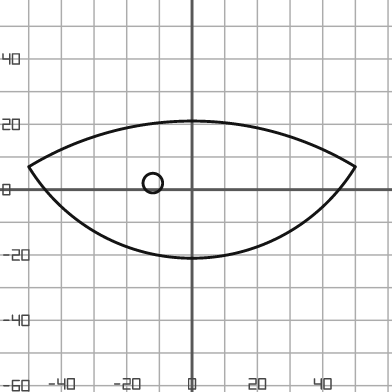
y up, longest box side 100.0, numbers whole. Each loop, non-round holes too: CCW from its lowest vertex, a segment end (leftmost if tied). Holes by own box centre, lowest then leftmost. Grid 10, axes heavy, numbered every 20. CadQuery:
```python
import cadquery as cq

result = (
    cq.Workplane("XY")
    .moveTo(-50.0, 7.0)
    .threePointArc((0.0, -21.0), (50.0, 7.0))
    .threePointArc((0.0, 21.0), (-50.0, 7.0))
    .close()
    .moveTo(-12.0, 2.0)
    .circle(3.0)
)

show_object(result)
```